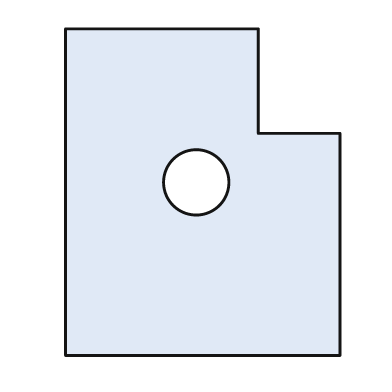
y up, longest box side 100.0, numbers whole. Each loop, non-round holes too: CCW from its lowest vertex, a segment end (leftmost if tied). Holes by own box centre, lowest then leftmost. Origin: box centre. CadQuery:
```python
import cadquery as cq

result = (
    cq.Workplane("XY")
    .moveTo(-42.0, -50.0)
    .lineTo(42.0, -50.0)
    .lineTo(42.0, 18.0)
    .lineTo(17.0, 18.0)
    .lineTo(17.0, 50.0)
    .lineTo(-42.0, 50.0)
    .close()
    .moveTo(-2.0, 3.0)
    .circle(10.0)
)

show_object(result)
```